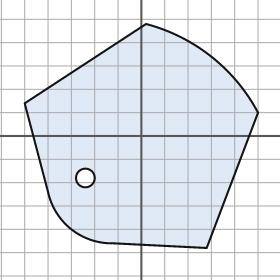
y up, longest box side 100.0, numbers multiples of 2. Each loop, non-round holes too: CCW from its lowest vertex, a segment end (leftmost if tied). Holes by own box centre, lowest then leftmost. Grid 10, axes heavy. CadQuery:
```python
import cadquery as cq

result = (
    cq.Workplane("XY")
    .moveTo(28.0, -48.0)
    .lineTo(50.0, 10.0)
    .threePointArc((30.0, 34.0), (2.0, 48.0))
    .lineTo(-50.0, 14.0)
    .lineTo(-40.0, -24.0)
    .threePointArc((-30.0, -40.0), (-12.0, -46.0))
    .close()
    .moveTo(-24.0, -18.0)
    .circle(4.0)
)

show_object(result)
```